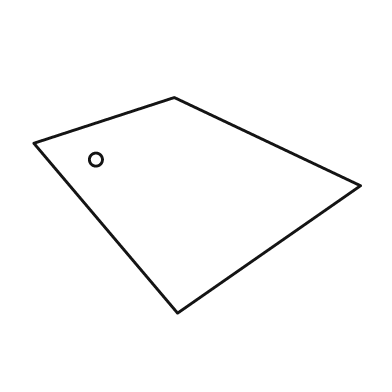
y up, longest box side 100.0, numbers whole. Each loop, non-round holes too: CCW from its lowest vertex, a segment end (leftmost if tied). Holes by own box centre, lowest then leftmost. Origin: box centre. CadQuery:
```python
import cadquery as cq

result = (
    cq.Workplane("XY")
    .moveTo(-6.0, -33.0)
    .lineTo(50.0, 6.0)
    .lineTo(-7.0, 33.0)
    .lineTo(-50.0, 19.0)
    .close()
    .moveTo(-31.0, 14.0)
    .circle(2.0)
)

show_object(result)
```